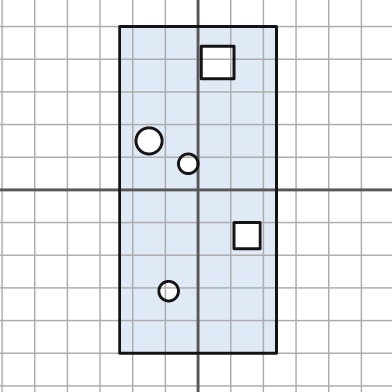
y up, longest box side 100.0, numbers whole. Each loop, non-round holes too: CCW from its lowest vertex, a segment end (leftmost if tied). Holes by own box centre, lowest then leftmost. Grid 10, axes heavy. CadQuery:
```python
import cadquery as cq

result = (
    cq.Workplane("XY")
    .moveTo(-24.0, -50.0)
    .lineTo(24.0, -50.0)
    .lineTo(24.0, 50.0)
    .lineTo(-24.0, 50.0)
    .close()
    .moveTo(-9.0, -31.0)
    .circle(3.0)
    .moveTo(11.0, -18.0)
    .lineTo(19.0, -18.0)
    .lineTo(19.0, -10.0)
    .lineTo(11.0, -10.0)
    .close()
    .moveTo(-3.0, 8.0)
    .circle(3.0)
    .moveTo(-15.0, 15.0)
    .circle(4.0)
    .moveTo(1.0, 34.0)
    .lineTo(11.0, 34.0)
    .lineTo(11.0, 44.0)
    .lineTo(1.0, 44.0)
    .close()
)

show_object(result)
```